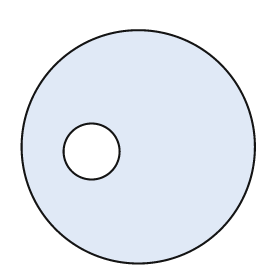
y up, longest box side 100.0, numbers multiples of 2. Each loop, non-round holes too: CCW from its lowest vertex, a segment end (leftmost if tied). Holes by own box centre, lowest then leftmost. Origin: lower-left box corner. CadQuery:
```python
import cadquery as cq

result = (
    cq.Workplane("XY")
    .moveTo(50.0, 50.0)
    .circle(50.0)
    .moveTo(30.0, 48.0)
    .circle(12.0)
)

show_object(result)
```